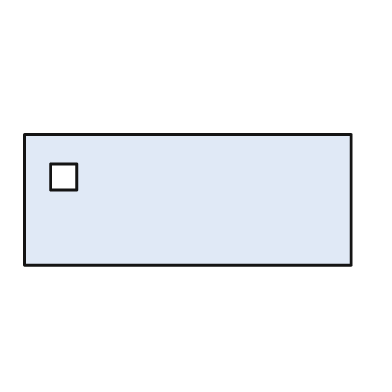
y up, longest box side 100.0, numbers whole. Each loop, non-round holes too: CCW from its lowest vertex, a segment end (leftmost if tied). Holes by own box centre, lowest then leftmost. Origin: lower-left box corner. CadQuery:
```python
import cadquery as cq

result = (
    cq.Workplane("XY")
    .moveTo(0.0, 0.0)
    .lineTo(100.0, 0.0)
    .lineTo(100.0, 40.0)
    .lineTo(0.0, 40.0)
    .close()
    .moveTo(8.0, 23.0)
    .lineTo(16.0, 23.0)
    .lineTo(16.0, 31.0)
    .lineTo(8.0, 31.0)
    .close()
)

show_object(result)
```